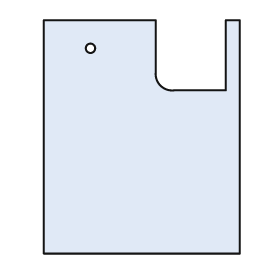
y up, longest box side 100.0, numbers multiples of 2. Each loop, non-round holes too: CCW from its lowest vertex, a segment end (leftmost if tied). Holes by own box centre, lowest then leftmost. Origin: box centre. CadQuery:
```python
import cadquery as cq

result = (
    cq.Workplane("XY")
    .moveTo(-42.0, -50.0)
    .lineTo(42.0, -50.0)
    .lineTo(42.0, 50.0)
    .lineTo(36.0, 50.0)
    .lineTo(36.0, 20.0)
    .lineTo(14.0, 20.0)
    .threePointArc((8.0, 22.0), (6.0, 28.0))
    .lineTo(6.0, 50.0)
    .lineTo(-42.0, 50.0)
    .close()
    .moveTo(-22.0, 38.0)
    .circle(2.0)
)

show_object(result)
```